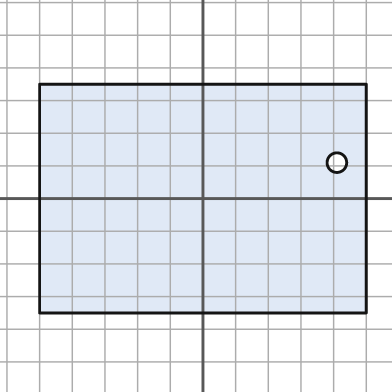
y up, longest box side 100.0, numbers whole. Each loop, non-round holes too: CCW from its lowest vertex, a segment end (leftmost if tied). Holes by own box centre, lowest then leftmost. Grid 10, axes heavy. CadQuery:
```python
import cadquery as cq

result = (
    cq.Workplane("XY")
    .moveTo(-50.0, -35.0)
    .lineTo(50.0, -35.0)
    .lineTo(50.0, 35.0)
    .lineTo(-50.0, 35.0)
    .close()
    .moveTo(41.0, 11.0)
    .circle(3.0)
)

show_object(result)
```